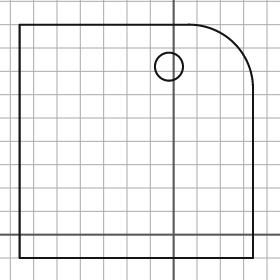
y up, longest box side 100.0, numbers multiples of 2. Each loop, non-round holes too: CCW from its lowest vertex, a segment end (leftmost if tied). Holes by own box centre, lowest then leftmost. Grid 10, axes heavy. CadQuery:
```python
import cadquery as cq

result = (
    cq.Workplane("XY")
    .moveTo(-66.0, -10.0)
    .lineTo(34.0, -10.0)
    .lineTo(34.0, 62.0)
    .threePointArc((26.0, 82.0), (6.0, 90.0))
    .lineTo(-66.0, 90.0)
    .close()
    .moveTo(-2.0, 72.0)
    .circle(6.0)
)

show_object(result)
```